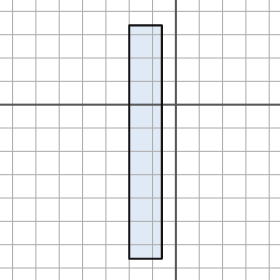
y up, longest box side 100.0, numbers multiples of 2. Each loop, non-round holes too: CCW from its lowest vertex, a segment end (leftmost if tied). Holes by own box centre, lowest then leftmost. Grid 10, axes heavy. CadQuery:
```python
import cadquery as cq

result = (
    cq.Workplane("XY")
    .moveTo(-20.0, -66.0)
    .lineTo(-6.0, -66.0)
    .lineTo(-6.0, 34.0)
    .lineTo(-20.0, 34.0)
    .close()
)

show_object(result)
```